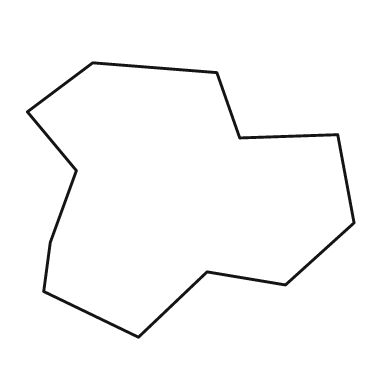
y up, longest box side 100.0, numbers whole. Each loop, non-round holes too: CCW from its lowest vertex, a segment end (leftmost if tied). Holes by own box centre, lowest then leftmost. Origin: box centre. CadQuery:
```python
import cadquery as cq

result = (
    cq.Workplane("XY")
    .moveTo(-16.0, -42.0)
    .lineTo(5.0, -22.0)
    .lineTo(29.0, -26.0)
    .lineTo(50.0, -7.0)
    .lineTo(45.0, 20.0)
    .lineTo(15.0, 19.0)
    .lineTo(8.0, 39.0)
    .lineTo(-30.0, 42.0)
    .lineTo(-50.0, 27.0)
    .lineTo(-35.0, 9.0)
    .lineTo(-43.0, -13.0)
    .lineTo(-45.0, -28.0)
    .close()
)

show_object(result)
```